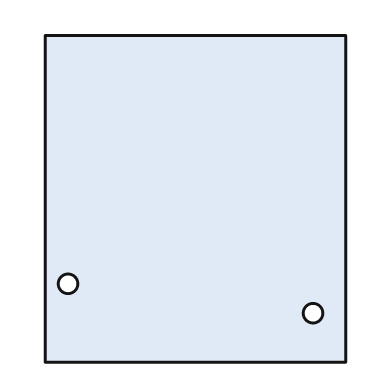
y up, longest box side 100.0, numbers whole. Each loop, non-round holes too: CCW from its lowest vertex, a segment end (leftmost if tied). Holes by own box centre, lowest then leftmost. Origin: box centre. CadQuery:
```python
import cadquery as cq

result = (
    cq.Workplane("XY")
    .moveTo(-46.0, -50.0)
    .lineTo(46.0, -50.0)
    .lineTo(46.0, 50.0)
    .lineTo(-46.0, 50.0)
    .close()
    .moveTo(36.0, -35.0)
    .circle(3.0)
    .moveTo(-39.0, -26.0)
    .circle(3.0)
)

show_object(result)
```